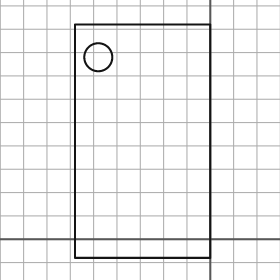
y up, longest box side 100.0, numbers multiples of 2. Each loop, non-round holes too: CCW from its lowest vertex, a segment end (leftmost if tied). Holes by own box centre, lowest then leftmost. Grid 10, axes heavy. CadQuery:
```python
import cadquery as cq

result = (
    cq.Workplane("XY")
    .moveTo(-58.0, -8.0)
    .lineTo(0.0, -8.0)
    .lineTo(0.0, 92.0)
    .lineTo(-58.0, 92.0)
    .close()
    .moveTo(-48.0, 78.0)
    .circle(6.0)
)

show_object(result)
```